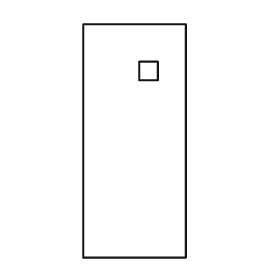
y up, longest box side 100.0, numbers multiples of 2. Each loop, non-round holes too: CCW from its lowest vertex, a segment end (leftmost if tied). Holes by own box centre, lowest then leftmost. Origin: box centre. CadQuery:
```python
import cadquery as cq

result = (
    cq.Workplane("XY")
    .moveTo(-22.0, -50.0)
    .lineTo(22.0, -50.0)
    .lineTo(22.0, 50.0)
    .lineTo(-22.0, 50.0)
    .close()
    .moveTo(2.0, 26.0)
    .lineTo(10.0, 26.0)
    .lineTo(10.0, 34.0)
    .lineTo(2.0, 34.0)
    .close()
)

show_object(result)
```